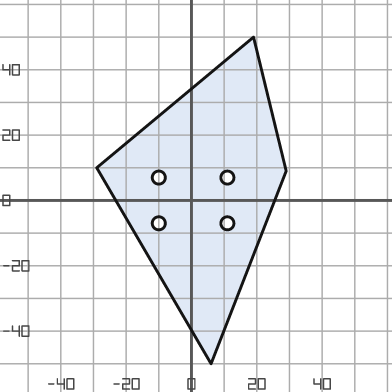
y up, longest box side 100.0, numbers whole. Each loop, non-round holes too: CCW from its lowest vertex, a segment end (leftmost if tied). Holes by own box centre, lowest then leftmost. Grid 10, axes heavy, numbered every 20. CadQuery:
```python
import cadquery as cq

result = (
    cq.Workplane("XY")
    .moveTo(6.0, -50.0)
    .lineTo(29.0, 9.0)
    .lineTo(19.0, 50.0)
    .lineTo(-29.0, 10.0)
    .close()
    .moveTo(-10.0, -7.0)
    .circle(2.0)
    .moveTo(11.0, -7.0)
    .circle(2.0)
    .moveTo(-10.0, 7.0)
    .circle(2.0)
    .moveTo(11.0, 7.0)
    .circle(2.0)
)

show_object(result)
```